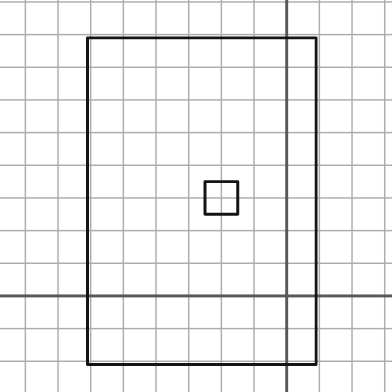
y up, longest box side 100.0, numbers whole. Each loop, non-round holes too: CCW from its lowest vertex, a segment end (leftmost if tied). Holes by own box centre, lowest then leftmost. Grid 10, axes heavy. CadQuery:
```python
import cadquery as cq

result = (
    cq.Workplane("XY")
    .moveTo(-61.0, -21.0)
    .lineTo(9.0, -21.0)
    .lineTo(9.0, 79.0)
    .lineTo(-61.0, 79.0)
    .close()
    .moveTo(-25.0, 25.0)
    .lineTo(-15.0, 25.0)
    .lineTo(-15.0, 35.0)
    .lineTo(-25.0, 35.0)
    .close()
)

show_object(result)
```